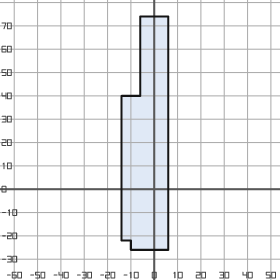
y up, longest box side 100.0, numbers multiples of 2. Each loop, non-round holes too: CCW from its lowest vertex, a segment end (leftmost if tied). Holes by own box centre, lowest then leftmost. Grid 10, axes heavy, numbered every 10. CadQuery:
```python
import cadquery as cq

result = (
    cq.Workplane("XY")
    .moveTo(-10.0, -26.0)
    .lineTo(6.0, -26.0)
    .lineTo(6.0, 74.0)
    .lineTo(-6.0, 74.0)
    .lineTo(-6.0, 40.0)
    .lineTo(-14.0, 40.0)
    .lineTo(-14.0, -22.0)
    .lineTo(-10.0, -22.0)
    .close()
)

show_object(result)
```